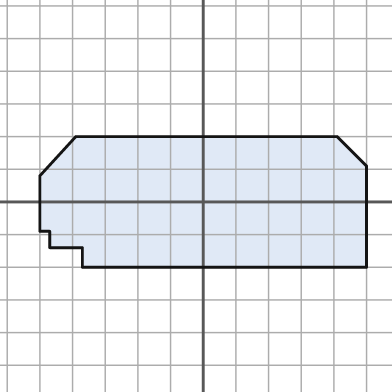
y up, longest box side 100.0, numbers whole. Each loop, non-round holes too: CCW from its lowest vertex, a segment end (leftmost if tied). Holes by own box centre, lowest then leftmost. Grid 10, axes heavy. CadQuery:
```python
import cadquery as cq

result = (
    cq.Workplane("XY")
    .moveTo(-37.0, -20.0)
    .lineTo(50.0, -20.0)
    .lineTo(50.0, 11.0)
    .lineTo(41.0, 20.0)
    .lineTo(-39.0, 20.0)
    .lineTo(-50.0, 8.0)
    .lineTo(-50.0, -9.0)
    .lineTo(-47.0, -9.0)
    .lineTo(-47.0, -14.0)
    .lineTo(-37.0, -14.0)
    .close()
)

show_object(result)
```